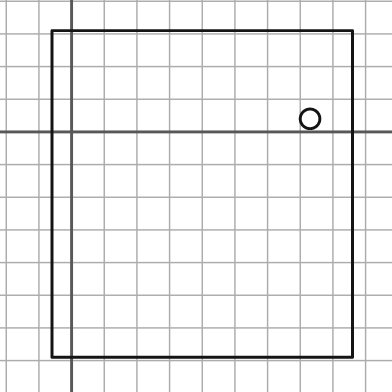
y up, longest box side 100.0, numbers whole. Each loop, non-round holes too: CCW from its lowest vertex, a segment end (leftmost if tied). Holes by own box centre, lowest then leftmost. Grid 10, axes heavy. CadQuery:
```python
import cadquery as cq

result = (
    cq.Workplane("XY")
    .moveTo(-6.0, -69.0)
    .lineTo(86.0, -69.0)
    .lineTo(86.0, 31.0)
    .lineTo(-6.0, 31.0)
    .close()
    .moveTo(73.0, 4.0)
    .circle(3.0)
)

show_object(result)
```